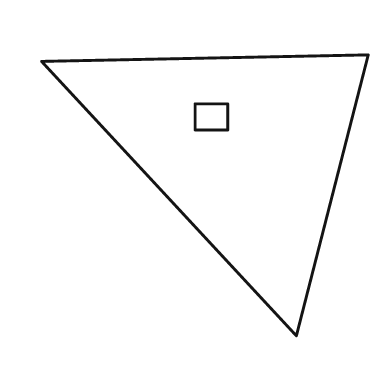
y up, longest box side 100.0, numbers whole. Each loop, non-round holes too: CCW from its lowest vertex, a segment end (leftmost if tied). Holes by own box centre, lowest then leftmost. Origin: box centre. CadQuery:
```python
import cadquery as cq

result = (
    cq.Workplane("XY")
    .moveTo(28.0, -43.0)
    .lineTo(50.0, 43.0)
    .lineTo(-50.0, 41.0)
    .close()
    .moveTo(-3.0, 20.0)
    .lineTo(7.0, 20.0)
    .lineTo(7.0, 28.0)
    .lineTo(-3.0, 28.0)
    .close()
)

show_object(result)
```